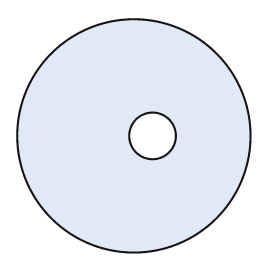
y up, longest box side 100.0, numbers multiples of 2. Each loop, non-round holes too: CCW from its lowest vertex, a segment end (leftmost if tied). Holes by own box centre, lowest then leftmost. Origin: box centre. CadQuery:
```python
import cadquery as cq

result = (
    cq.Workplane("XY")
    .moveTo(0.0, 0.0)
    .circle(50.0)
    .moveTo(8.0, 0.0)
    .circle(10.0)
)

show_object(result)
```